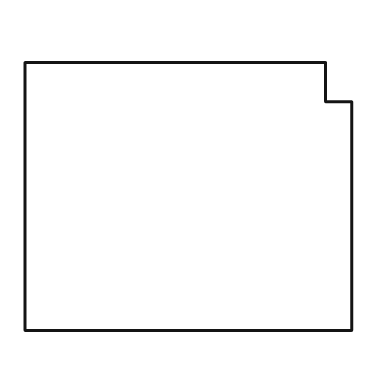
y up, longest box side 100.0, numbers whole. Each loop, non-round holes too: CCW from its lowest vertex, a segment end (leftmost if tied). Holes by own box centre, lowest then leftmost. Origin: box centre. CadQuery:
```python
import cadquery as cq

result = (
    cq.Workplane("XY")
    .moveTo(-50.0, -41.0)
    .lineTo(50.0, -41.0)
    .lineTo(50.0, 29.0)
    .lineTo(42.0, 29.0)
    .lineTo(42.0, 41.0)
    .lineTo(-50.0, 41.0)
    .close()
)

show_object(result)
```